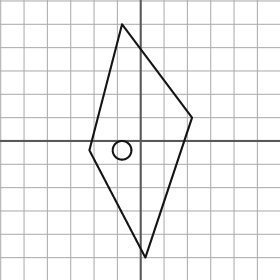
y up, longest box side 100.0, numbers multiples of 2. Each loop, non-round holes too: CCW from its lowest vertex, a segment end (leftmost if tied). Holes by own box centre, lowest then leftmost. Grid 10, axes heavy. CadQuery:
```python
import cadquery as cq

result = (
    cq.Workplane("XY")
    .moveTo(2.0, -50.0)
    .lineTo(22.0, 10.0)
    .lineTo(-8.0, 50.0)
    .lineTo(-22.0, -4.0)
    .close()
    .moveTo(-8.0, -4.0)
    .circle(4.0)
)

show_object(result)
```